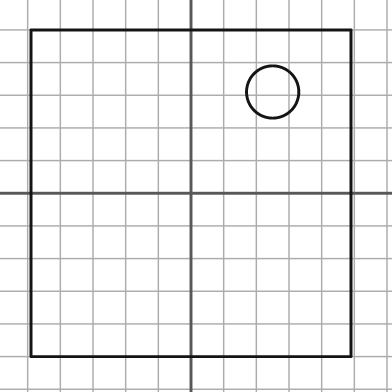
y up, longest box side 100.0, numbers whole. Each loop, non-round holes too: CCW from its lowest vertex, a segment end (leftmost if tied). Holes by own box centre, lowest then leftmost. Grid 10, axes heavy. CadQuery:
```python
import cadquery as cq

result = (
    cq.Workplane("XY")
    .moveTo(-49.0, -50.0)
    .lineTo(49.0, -50.0)
    .lineTo(49.0, 50.0)
    .lineTo(-49.0, 50.0)
    .close()
    .moveTo(25.0, 31.0)
    .circle(8.0)
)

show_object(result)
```